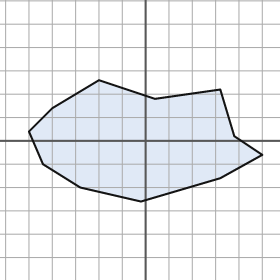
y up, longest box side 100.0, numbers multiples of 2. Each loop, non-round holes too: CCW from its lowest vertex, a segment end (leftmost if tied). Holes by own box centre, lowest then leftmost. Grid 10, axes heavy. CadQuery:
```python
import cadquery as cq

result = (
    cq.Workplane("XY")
    .moveTo(-2.0, -26.0)
    .lineTo(32.0, -16.0)
    .lineTo(50.0, -6.0)
    .lineTo(38.0, 2.0)
    .lineTo(32.0, 22.0)
    .lineTo(4.0, 18.0)
    .lineTo(-20.0, 26.0)
    .lineTo(-40.0, 14.0)
    .lineTo(-50.0, 4.0)
    .lineTo(-44.0, -10.0)
    .lineTo(-28.0, -20.0)
    .close()
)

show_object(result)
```